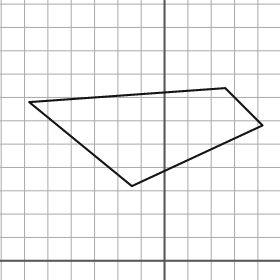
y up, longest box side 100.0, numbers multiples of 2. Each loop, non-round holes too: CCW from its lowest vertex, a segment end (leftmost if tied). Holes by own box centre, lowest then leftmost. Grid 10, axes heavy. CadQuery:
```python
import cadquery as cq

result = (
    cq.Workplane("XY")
    .moveTo(-14.0, 32.0)
    .lineTo(42.0, 58.0)
    .lineTo(26.0, 74.0)
    .lineTo(-58.0, 68.0)
    .close()
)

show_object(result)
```